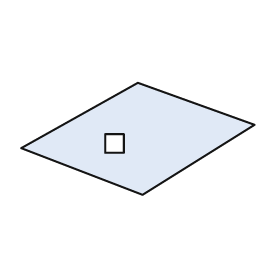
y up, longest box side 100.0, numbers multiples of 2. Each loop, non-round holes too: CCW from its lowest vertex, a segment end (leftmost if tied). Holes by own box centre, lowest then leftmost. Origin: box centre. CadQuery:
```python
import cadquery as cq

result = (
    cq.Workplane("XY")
    .moveTo(2.0, -24.0)
    .lineTo(50.0, 6.0)
    .lineTo(0.0, 24.0)
    .lineTo(-50.0, -4.0)
    .close()
    .moveTo(-14.0, -6.0)
    .lineTo(-6.0, -6.0)
    .lineTo(-6.0, 2.0)
    .lineTo(-14.0, 2.0)
    .close()
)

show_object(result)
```